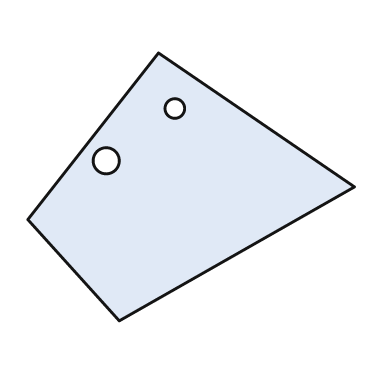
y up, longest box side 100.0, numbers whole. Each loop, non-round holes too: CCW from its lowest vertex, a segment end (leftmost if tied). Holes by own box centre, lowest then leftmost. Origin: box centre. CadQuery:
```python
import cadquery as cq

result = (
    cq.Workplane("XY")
    .moveTo(-22.0, -41.0)
    .lineTo(50.0, 0.0)
    .lineTo(-10.0, 41.0)
    .lineTo(-50.0, -10.0)
    .close()
    .moveTo(-26.0, 8.0)
    .circle(4.0)
    .moveTo(-5.0, 24.0)
    .circle(3.0)
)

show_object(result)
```